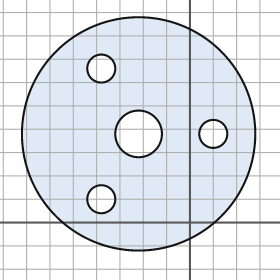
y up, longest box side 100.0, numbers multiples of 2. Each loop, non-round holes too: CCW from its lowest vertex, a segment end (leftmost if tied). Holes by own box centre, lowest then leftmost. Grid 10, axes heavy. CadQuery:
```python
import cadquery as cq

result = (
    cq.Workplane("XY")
    .moveTo(-22.0, 38.0)
    .circle(50.0)
    .moveTo(-38.0, 10.0)
    .circle(6.0)
    .moveTo(-22.0, 38.0)
    .circle(10.0)
    .moveTo(10.0, 38.0)
    .circle(6.0)
    .moveTo(-38.0, 66.0)
    .circle(6.0)
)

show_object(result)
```